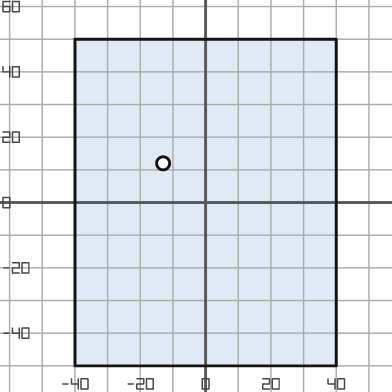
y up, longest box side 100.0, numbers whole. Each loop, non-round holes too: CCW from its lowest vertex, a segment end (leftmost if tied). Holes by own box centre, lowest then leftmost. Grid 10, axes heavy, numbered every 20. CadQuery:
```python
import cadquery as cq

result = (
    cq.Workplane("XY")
    .moveTo(-40.0, -50.0)
    .lineTo(40.0, -50.0)
    .lineTo(40.0, 50.0)
    .lineTo(-40.0, 50.0)
    .close()
    .moveTo(-13.0, 12.0)
    .circle(2.0)
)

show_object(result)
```